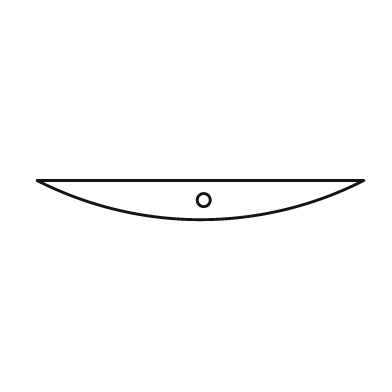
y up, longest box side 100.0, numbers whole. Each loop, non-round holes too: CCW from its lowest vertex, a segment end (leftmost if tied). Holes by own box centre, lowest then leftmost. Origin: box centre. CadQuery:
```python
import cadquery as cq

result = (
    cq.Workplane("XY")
    .moveTo(-50.0, 6.0)
    .threePointArc((0.0, -6.0), (50.0, 6.0))
    .close()
    .moveTo(1.0, 0.0)
    .circle(2.0)
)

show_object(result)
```